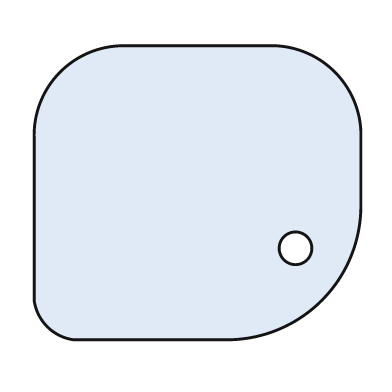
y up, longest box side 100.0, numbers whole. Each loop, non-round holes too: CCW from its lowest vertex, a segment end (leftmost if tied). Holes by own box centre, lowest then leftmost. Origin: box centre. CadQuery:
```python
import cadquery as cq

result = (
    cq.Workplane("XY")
    .moveTo(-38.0, -45.0)
    .lineTo(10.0, -45.0)
    .threePointArc((38.0, -33.0), (50.0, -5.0))
    .lineTo(50.0, 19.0)
    .threePointArc((42.0, 37.0), (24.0, 45.0))
    .lineTo(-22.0, 45.0)
    .threePointArc((-42.0, 37.0), (-50.0, 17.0))
    .lineTo(-50.0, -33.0)
    .threePointArc((-46.0, -41.0), (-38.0, -45.0))
    .close()
    .moveTo(30.0, -17.0)
    .circle(5.0)
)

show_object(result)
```